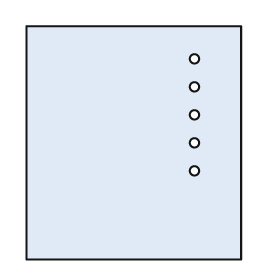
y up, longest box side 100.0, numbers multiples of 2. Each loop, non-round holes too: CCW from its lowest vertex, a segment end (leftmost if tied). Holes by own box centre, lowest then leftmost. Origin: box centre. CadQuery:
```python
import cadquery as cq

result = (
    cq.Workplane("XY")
    .moveTo(-46.0, -50.0)
    .lineTo(46.0, -50.0)
    .lineTo(46.0, 50.0)
    .lineTo(-46.0, 50.0)
    .close()
    .moveTo(26.0, -12.0)
    .circle(2.0)
    .moveTo(26.0, 0.0)
    .circle(2.0)
    .moveTo(26.0, 12.0)
    .circle(2.0)
    .moveTo(26.0, 24.0)
    .circle(2.0)
    .moveTo(26.0, 36.0)
    .circle(2.0)
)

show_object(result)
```